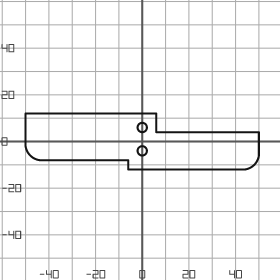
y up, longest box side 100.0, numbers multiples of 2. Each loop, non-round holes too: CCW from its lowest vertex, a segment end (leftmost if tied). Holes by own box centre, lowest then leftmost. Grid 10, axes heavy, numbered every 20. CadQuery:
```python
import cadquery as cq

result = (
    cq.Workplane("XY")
    .moveTo(-6.0, -12.0)
    .lineTo(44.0, -12.0)
    .threePointArc((48.0, -10.0), (50.0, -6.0))
    .lineTo(50.0, 4.0)
    .lineTo(6.0, 4.0)
    .lineTo(6.0, 12.0)
    .lineTo(-50.0, 12.0)
    .lineTo(-50.0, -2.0)
    .threePointArc((-48.0, -6.0), (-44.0, -8.0))
    .lineTo(-6.0, -8.0)
    .close()
    .moveTo(0.0, -4.0)
    .circle(2.0)
    .moveTo(0.0, 6.0)
    .circle(2.0)
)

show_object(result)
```